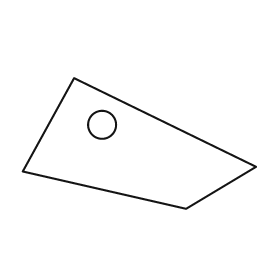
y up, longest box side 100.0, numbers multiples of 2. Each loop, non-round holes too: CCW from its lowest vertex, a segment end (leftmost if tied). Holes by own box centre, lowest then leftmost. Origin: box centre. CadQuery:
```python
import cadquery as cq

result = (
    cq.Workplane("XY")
    .moveTo(20.0, -28.0)
    .lineTo(50.0, -10.0)
    .lineTo(-28.0, 28.0)
    .lineTo(-50.0, -12.0)
    .close()
    .moveTo(-16.0, 8.0)
    .circle(6.0)
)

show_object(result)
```